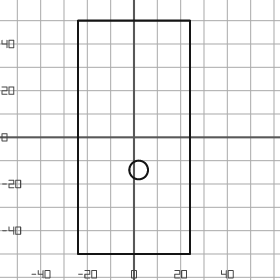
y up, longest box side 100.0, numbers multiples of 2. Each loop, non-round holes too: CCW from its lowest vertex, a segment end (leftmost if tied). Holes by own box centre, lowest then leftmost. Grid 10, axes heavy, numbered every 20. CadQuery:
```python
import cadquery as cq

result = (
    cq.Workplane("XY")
    .moveTo(-24.0, -50.0)
    .lineTo(24.0, -50.0)
    .lineTo(24.0, 50.0)
    .lineTo(-24.0, 50.0)
    .close()
    .moveTo(2.0, -14.0)
    .circle(4.0)
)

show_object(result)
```